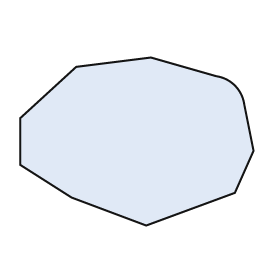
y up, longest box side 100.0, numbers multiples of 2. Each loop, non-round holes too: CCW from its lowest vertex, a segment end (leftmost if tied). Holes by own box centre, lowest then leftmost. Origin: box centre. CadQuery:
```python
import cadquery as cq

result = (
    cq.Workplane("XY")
    .moveTo(4.0, -36.0)
    .lineTo(42.0, -22.0)
    .lineTo(50.0, -4.0)
    .lineTo(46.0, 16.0)
    .threePointArc((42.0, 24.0), (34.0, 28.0))
    .lineTo(6.0, 36.0)
    .lineTo(-26.0, 32.0)
    .lineTo(-50.0, 10.0)
    .lineTo(-50.0, -10.0)
    .lineTo(-28.0, -24.0)
    .close()
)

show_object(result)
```